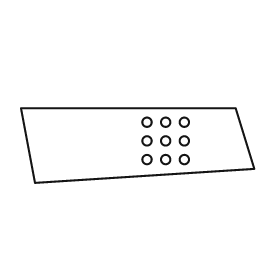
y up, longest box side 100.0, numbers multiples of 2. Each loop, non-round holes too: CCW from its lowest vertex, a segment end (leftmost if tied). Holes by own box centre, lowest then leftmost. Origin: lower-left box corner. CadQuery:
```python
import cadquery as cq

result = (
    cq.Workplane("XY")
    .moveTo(6.0, 0.0)
    .lineTo(100.0, 6.0)
    .lineTo(92.0, 32.0)
    .lineTo(0.0, 32.0)
    .close()
    .moveTo(54.0, 10.0)
    .circle(2.0)
    .moveTo(62.0, 10.0)
    .circle(2.0)
    .moveTo(70.0, 10.0)
    .circle(2.0)
    .moveTo(54.0, 18.0)
    .circle(2.0)
    .moveTo(62.0, 18.0)
    .circle(2.0)
    .moveTo(70.0, 18.0)
    .circle(2.0)
    .moveTo(54.0, 26.0)
    .circle(2.0)
    .moveTo(62.0, 26.0)
    .circle(2.0)
    .moveTo(70.0, 26.0)
    .circle(2.0)
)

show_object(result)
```